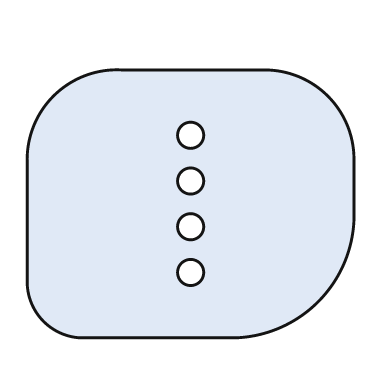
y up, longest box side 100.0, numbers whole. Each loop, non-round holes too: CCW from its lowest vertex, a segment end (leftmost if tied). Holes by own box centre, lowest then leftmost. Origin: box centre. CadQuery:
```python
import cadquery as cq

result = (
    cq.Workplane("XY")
    .moveTo(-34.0, -41.0)
    .lineTo(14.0, -41.0)
    .threePointArc((39.0, -30.0), (50.0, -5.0))
    .lineTo(50.0, 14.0)
    .threePointArc((42.0, 33.0), (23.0, 41.0))
    .lineTo(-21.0, 41.0)
    .threePointArc((-42.0, 33.0), (-50.0, 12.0))
    .lineTo(-50.0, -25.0)
    .threePointArc((-45.0, -36.0), (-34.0, -41.0))
    .close()
    .moveTo(0.0, -21.0)
    .circle(4.0)
    .moveTo(0.0, -7.0)
    .circle(4.0)
    .moveTo(0.0, 7.0)
    .circle(4.0)
    .moveTo(0.0, 21.0)
    .circle(4.0)
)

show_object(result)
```